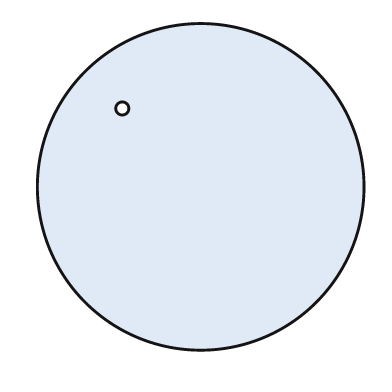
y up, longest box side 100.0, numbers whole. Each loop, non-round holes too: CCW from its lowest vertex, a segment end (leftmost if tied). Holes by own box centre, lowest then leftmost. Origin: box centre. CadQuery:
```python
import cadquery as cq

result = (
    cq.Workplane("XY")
    .moveTo(0.0, 0.0)
    .circle(50.0)
    .moveTo(-24.0, 24.0)
    .circle(2.0)
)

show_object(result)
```